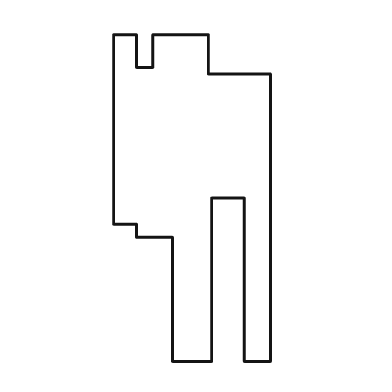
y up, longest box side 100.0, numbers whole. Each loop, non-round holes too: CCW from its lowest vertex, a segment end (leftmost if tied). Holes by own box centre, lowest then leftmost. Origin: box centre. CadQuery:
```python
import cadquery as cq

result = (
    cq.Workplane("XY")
    .moveTo(-6.0, -50.0)
    .lineTo(6.0, -50.0)
    .lineTo(6.0, 0.0)
    .lineTo(16.0, 0.0)
    .lineTo(16.0, -50.0)
    .lineTo(24.0, -50.0)
    .lineTo(24.0, 38.0)
    .lineTo(5.0, 38.0)
    .lineTo(5.0, 50.0)
    .lineTo(-12.0, 50.0)
    .lineTo(-12.0, 40.0)
    .lineTo(-17.0, 40.0)
    .lineTo(-17.0, 50.0)
    .lineTo(-24.0, 50.0)
    .lineTo(-24.0, -8.0)
    .lineTo(-17.0, -8.0)
    .lineTo(-17.0, -12.0)
    .lineTo(-6.0, -12.0)
    .close()
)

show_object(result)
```